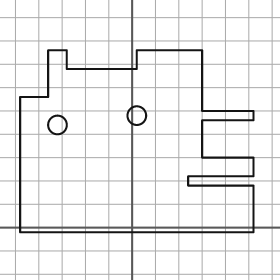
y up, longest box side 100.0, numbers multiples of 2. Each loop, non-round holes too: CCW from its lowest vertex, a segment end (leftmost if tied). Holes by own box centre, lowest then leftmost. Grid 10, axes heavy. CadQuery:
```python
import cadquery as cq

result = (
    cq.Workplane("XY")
    .moveTo(-48.0, -2.0)
    .lineTo(52.0, -2.0)
    .lineTo(52.0, 18.0)
    .lineTo(24.0, 18.0)
    .lineTo(24.0, 22.0)
    .lineTo(52.0, 22.0)
    .lineTo(52.0, 30.0)
    .lineTo(30.0, 30.0)
    .lineTo(30.0, 46.0)
    .lineTo(52.0, 46.0)
    .lineTo(52.0, 50.0)
    .lineTo(30.0, 50.0)
    .lineTo(30.0, 76.0)
    .lineTo(2.0, 76.0)
    .lineTo(2.0, 68.0)
    .lineTo(-28.0, 68.0)
    .lineTo(-28.0, 76.0)
    .lineTo(-36.0, 76.0)
    .lineTo(-36.0, 56.0)
    .lineTo(-48.0, 56.0)
    .close()
    .moveTo(-32.0, 44.0)
    .circle(4.0)
    .moveTo(2.0, 48.0)
    .circle(4.0)
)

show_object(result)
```